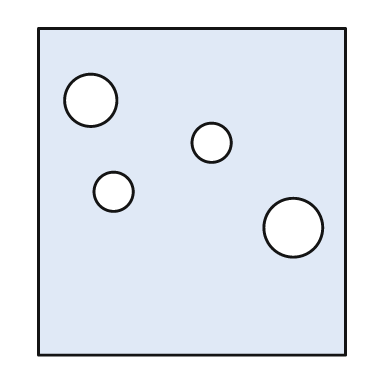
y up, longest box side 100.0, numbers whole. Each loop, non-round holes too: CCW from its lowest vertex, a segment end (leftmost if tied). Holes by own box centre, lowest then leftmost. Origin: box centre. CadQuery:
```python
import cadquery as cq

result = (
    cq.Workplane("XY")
    .moveTo(-47.0, -50.0)
    .lineTo(47.0, -50.0)
    .lineTo(47.0, 50.0)
    .lineTo(-47.0, 50.0)
    .close()
    .moveTo(31.0, -11.0)
    .circle(9.0)
    .moveTo(-24.0, 0.0)
    .circle(6.0)
    .moveTo(6.0, 15.0)
    .circle(6.0)
    .moveTo(-31.0, 28.0)
    .circle(8.0)
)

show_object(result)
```